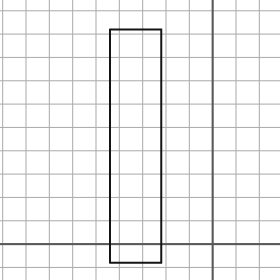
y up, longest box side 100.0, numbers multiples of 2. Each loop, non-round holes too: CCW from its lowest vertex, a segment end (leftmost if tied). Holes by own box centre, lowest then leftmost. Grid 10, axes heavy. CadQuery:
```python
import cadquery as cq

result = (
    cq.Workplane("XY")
    .moveTo(-44.0, -8.0)
    .lineTo(-22.0, -8.0)
    .lineTo(-22.0, 92.0)
    .lineTo(-44.0, 92.0)
    .close()
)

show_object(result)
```